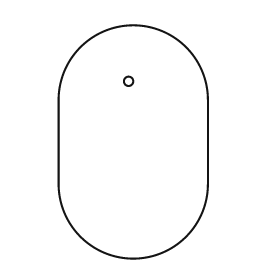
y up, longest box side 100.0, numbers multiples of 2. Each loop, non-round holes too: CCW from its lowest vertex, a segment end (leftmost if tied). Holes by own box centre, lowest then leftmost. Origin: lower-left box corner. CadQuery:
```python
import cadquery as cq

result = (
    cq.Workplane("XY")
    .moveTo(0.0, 32.0)
    .threePointArc((32.0, 0.0), (64.0, 32.0))
    .lineTo(64.0, 68.0)
    .threePointArc((32.0, 100.0), (0.0, 68.0))
    .close()
    .moveTo(30.0, 76.0)
    .circle(2.0)
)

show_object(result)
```